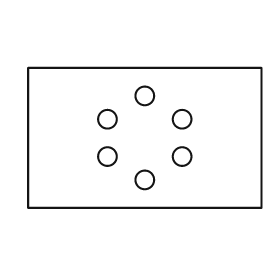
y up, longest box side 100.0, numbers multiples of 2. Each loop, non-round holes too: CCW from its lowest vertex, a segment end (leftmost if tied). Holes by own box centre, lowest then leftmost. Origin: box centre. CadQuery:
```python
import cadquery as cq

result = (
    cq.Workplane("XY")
    .moveTo(-50.0, -30.0)
    .lineTo(50.0, -30.0)
    .lineTo(50.0, 30.0)
    .lineTo(-50.0, 30.0)
    .close()
    .moveTo(0.0, -18.0)
    .circle(4.0)
    .moveTo(-16.0, -8.0)
    .circle(4.0)
    .moveTo(16.0, -8.0)
    .circle(4.0)
    .moveTo(-16.0, 8.0)
    .circle(4.0)
    .moveTo(16.0, 8.0)
    .circle(4.0)
    .moveTo(0.0, 18.0)
    .circle(4.0)
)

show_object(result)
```